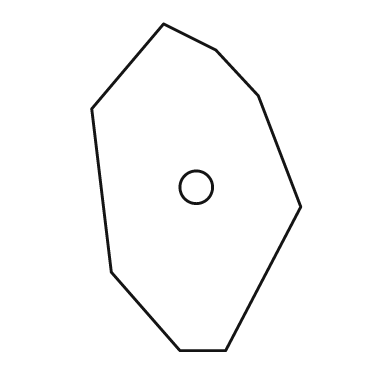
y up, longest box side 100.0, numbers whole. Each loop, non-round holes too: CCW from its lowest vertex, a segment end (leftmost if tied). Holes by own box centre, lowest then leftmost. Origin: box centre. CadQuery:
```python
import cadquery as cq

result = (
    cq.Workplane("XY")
    .moveTo(-5.0, -50.0)
    .lineTo(9.0, -50.0)
    .lineTo(32.0, -6.0)
    .lineTo(19.0, 28.0)
    .lineTo(6.0, 42.0)
    .lineTo(-10.0, 50.0)
    .lineTo(-32.0, 24.0)
    .lineTo(-26.0, -26.0)
    .close()
    .moveTo(0.0, 0.0)
    .circle(5.0)
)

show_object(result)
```